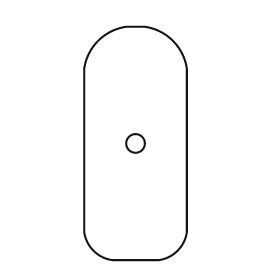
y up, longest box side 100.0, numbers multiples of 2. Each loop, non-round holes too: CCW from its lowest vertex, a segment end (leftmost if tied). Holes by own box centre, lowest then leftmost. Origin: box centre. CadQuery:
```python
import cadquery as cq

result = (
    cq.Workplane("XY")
    .moveTo(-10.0, -50.0)
    .lineTo(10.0, -50.0)
    .threePointArc((18.0, -46.0), (22.0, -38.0))
    .lineTo(22.0, 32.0)
    .threePointArc((16.0, 44.0), (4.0, 50.0))
    .lineTo(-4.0, 50.0)
    .threePointArc((-16.0, 44.0), (-22.0, 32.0))
    .lineTo(-22.0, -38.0)
    .threePointArc((-18.0, -46.0), (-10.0, -50.0))
    .close()
    .moveTo(0.0, 0.0)
    .circle(4.0)
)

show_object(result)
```